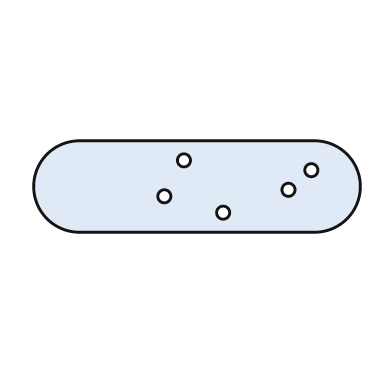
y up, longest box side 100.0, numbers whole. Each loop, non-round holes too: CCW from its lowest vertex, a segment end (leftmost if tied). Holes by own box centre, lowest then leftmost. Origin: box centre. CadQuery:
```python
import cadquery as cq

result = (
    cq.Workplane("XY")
    .moveTo(-36.0, -14.0)
    .lineTo(36.0, -14.0)
    .threePointArc((50.0, 0.0), (36.0, 14.0))
    .lineTo(-36.0, 14.0)
    .threePointArc((-50.0, 0.0), (-36.0, -14.0))
    .close()
    .moveTo(8.0, -8.0)
    .circle(2.0)
    .moveTo(-10.0, -3.0)
    .circle(2.0)
    .moveTo(28.0, -1.0)
    .circle(2.0)
    .moveTo(35.0, 5.0)
    .circle(2.0)
    .moveTo(-4.0, 8.0)
    .circle(2.0)
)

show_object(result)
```